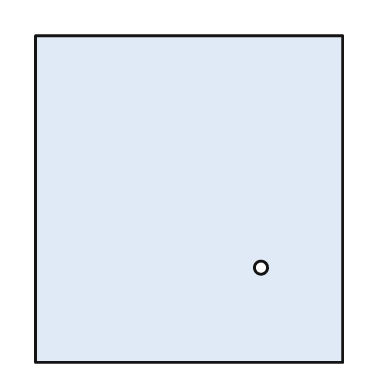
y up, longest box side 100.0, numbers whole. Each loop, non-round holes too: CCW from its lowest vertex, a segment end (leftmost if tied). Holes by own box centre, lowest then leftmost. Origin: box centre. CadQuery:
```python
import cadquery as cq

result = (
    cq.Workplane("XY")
    .moveTo(-47.0, -50.0)
    .lineTo(47.0, -50.0)
    .lineTo(47.0, 50.0)
    .lineTo(-47.0, 50.0)
    .close()
    .moveTo(22.0, -21.0)
    .circle(2.0)
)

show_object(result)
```